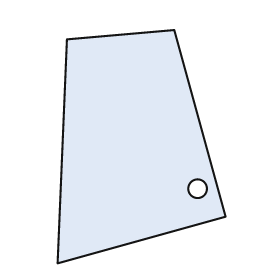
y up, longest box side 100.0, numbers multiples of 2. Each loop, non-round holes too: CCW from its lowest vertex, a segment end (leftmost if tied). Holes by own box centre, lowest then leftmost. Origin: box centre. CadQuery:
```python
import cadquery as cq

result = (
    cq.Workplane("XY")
    .moveTo(-36.0, -50.0)
    .lineTo(36.0, -30.0)
    .lineTo(14.0, 50.0)
    .lineTo(-32.0, 46.0)
    .close()
    .moveTo(24.0, -18.0)
    .circle(4.0)
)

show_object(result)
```